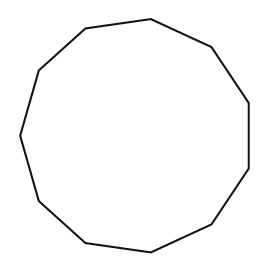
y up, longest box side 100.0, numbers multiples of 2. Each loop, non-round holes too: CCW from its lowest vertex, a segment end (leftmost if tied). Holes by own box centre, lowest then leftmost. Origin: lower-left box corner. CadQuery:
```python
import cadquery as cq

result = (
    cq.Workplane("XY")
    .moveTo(56.0, 0.0)
    .lineTo(82.0, 12.0)
    .lineTo(98.0, 36.0)
    .lineTo(98.0, 64.0)
    .lineTo(82.0, 88.0)
    .lineTo(56.0, 100.0)
    .lineTo(28.0, 96.0)
    .lineTo(8.0, 78.0)
    .lineTo(0.0, 50.0)
    .lineTo(8.0, 22.0)
    .lineTo(28.0, 4.0)
    .close()
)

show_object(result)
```